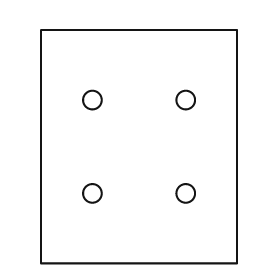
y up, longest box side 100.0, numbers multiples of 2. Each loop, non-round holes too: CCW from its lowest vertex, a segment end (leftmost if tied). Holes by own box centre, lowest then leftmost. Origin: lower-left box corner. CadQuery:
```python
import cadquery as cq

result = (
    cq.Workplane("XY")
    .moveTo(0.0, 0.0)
    .lineTo(84.0, 0.0)
    .lineTo(84.0, 100.0)
    .lineTo(0.0, 100.0)
    .close()
    .moveTo(22.0, 30.0)
    .circle(4.0)
    .moveTo(62.0, 30.0)
    .circle(4.0)
    .moveTo(22.0, 70.0)
    .circle(4.0)
    .moveTo(62.0, 70.0)
    .circle(4.0)
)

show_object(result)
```